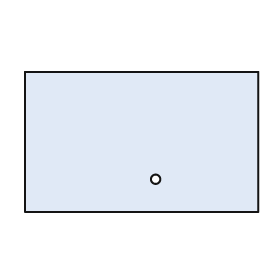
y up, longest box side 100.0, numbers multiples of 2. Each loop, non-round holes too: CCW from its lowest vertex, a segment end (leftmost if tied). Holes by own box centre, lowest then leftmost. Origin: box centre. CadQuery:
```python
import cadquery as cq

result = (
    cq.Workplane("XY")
    .moveTo(-50.0, -30.0)
    .lineTo(50.0, -30.0)
    .lineTo(50.0, 30.0)
    .lineTo(-50.0, 30.0)
    .close()
    .moveTo(6.0, -16.0)
    .circle(2.0)
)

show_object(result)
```